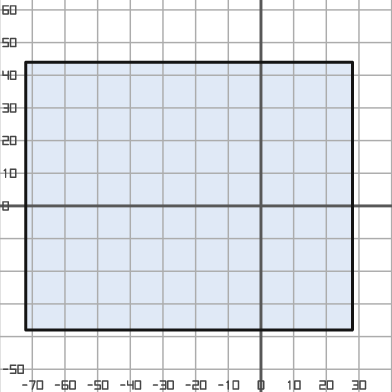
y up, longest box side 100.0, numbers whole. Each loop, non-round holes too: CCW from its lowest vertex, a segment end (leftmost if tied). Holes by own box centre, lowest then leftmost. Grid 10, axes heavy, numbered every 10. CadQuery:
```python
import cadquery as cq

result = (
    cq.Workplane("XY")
    .moveTo(-72.0, -38.0)
    .lineTo(28.0, -38.0)
    .lineTo(28.0, 44.0)
    .lineTo(-72.0, 44.0)
    .close()
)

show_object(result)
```